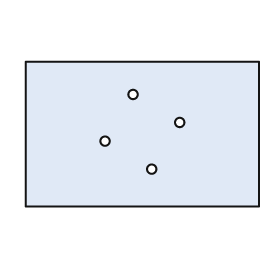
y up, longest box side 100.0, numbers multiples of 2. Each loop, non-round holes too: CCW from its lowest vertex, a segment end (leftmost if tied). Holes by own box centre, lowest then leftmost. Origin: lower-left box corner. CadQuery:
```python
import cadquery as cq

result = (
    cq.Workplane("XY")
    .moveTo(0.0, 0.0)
    .lineTo(100.0, 0.0)
    .lineTo(100.0, 62.0)
    .lineTo(0.0, 62.0)
    .close()
    .moveTo(54.0, 16.0)
    .circle(2.0)
    .moveTo(34.0, 28.0)
    .circle(2.0)
    .moveTo(66.0, 36.0)
    .circle(2.0)
    .moveTo(46.0, 48.0)
    .circle(2.0)
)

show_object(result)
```